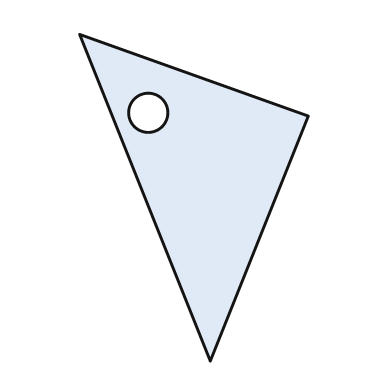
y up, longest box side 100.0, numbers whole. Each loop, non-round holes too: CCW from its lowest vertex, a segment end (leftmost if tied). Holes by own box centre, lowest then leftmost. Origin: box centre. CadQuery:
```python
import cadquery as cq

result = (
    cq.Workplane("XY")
    .moveTo(5.0, -50.0)
    .lineTo(35.0, 25.0)
    .lineTo(-35.0, 50.0)
    .close()
    .moveTo(-14.0, 26.0)
    .circle(6.0)
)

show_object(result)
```